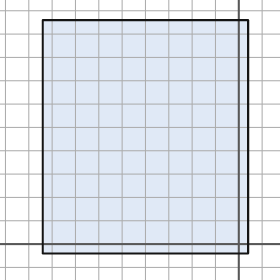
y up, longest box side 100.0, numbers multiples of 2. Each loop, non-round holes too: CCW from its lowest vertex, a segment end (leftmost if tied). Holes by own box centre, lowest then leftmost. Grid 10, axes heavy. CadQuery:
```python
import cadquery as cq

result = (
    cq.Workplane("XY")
    .moveTo(-84.0, -4.0)
    .lineTo(4.0, -4.0)
    .lineTo(4.0, 96.0)
    .lineTo(-84.0, 96.0)
    .close()
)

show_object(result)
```